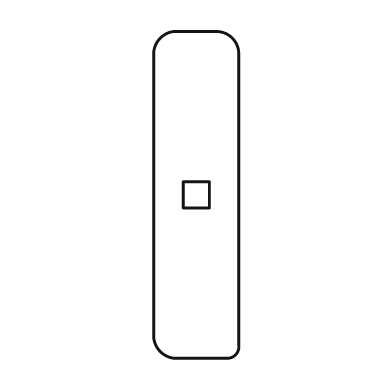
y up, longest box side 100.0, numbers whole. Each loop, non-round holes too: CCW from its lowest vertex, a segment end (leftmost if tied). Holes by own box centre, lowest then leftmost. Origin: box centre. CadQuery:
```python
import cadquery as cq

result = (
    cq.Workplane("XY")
    .moveTo(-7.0, -50.0)
    .lineTo(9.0, -50.0)
    .threePointArc((12.0, -49.0), (13.0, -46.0))
    .lineTo(13.0, 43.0)
    .threePointArc((11.0, 48.0), (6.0, 50.0))
    .lineTo(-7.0, 50.0)
    .threePointArc((-11.0, 48.0), (-13.0, 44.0))
    .lineTo(-13.0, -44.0)
    .threePointArc((-11.0, -48.0), (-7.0, -50.0))
    .close()
    .moveTo(-4.0, -4.0)
    .lineTo(4.0, -4.0)
    .lineTo(4.0, 4.0)
    .lineTo(-4.0, 4.0)
    .close()
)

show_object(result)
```